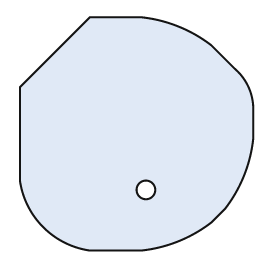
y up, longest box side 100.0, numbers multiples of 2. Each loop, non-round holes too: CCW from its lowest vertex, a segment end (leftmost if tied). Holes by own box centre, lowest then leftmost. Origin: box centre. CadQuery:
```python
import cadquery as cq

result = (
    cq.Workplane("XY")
    .moveTo(-20.0, -50.0)
    .lineTo(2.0, -50.0)
    .threePointArc((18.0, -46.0), (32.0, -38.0))
    .lineTo(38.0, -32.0)
    .threePointArc((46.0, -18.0), (50.0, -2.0))
    .lineTo(50.0, 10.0)
    .threePointArc((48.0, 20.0), (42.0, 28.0))
    .lineTo(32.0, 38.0)
    .threePointArc((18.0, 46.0), (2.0, 50.0))
    .lineTo(-20.0, 50.0)
    .lineTo(-50.0, 20.0)
    .lineTo(-50.0, -20.0)
    .threePointArc((-40.0, -40.0), (-20.0, -50.0))
    .close()
    .moveTo(4.0, -24.0)
    .circle(4.0)
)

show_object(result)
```